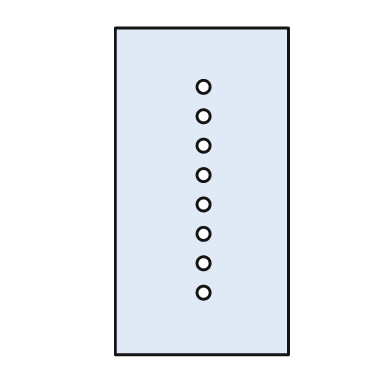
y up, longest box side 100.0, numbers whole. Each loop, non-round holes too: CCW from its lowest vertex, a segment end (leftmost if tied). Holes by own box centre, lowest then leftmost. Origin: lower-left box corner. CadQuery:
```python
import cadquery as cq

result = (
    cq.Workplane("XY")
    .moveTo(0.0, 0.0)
    .lineTo(53.0, 0.0)
    .lineTo(53.0, 100.0)
    .lineTo(0.0, 100.0)
    .close()
    .moveTo(27.0, 19.0)
    .circle(2.0)
    .moveTo(27.0, 28.0)
    .circle(2.0)
    .moveTo(27.0, 37.0)
    .circle(2.0)
    .moveTo(27.0, 46.0)
    .circle(2.0)
    .moveTo(27.0, 55.0)
    .circle(2.0)
    .moveTo(27.0, 64.0)
    .circle(2.0)
    .moveTo(27.0, 73.0)
    .circle(2.0)
    .moveTo(27.0, 82.0)
    .circle(2.0)
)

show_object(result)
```